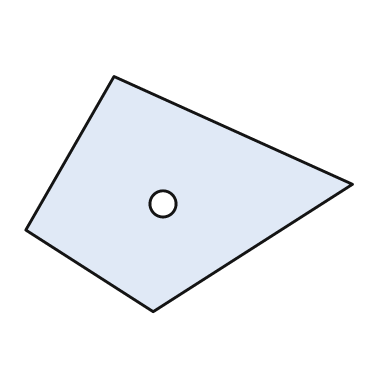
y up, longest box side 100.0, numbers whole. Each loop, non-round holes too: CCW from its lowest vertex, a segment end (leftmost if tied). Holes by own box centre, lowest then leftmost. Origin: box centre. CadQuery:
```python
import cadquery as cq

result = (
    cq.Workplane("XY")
    .moveTo(-11.0, -36.0)
    .lineTo(50.0, 3.0)
    .lineTo(-23.0, 36.0)
    .lineTo(-50.0, -11.0)
    .close()
    .moveTo(-8.0, -3.0)
    .circle(4.0)
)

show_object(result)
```